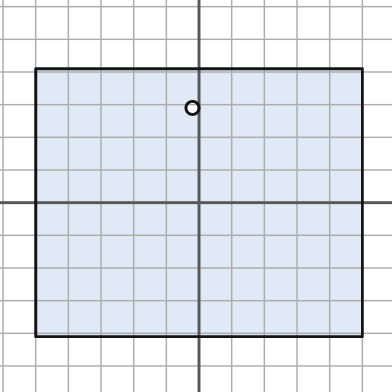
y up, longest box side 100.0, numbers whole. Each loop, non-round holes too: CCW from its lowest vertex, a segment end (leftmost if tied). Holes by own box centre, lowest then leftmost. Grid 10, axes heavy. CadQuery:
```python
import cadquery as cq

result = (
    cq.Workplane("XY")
    .moveTo(-50.0, -41.0)
    .lineTo(50.0, -41.0)
    .lineTo(50.0, 41.0)
    .lineTo(-50.0, 41.0)
    .close()
    .moveTo(-2.0, 29.0)
    .circle(2.0)
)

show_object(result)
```